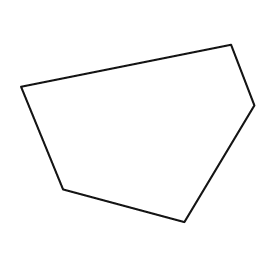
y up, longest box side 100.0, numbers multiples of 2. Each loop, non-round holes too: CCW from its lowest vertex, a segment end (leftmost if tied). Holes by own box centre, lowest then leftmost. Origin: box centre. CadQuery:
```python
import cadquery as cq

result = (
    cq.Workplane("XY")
    .moveTo(20.0, -38.0)
    .lineTo(50.0, 12.0)
    .lineTo(40.0, 38.0)
    .lineTo(-50.0, 20.0)
    .lineTo(-32.0, -24.0)
    .close()
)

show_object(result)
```